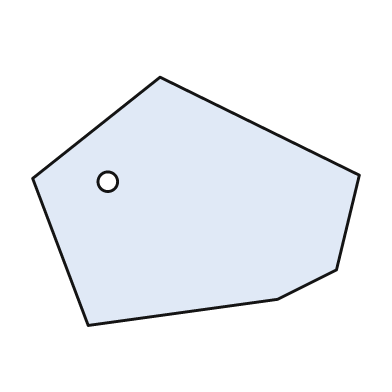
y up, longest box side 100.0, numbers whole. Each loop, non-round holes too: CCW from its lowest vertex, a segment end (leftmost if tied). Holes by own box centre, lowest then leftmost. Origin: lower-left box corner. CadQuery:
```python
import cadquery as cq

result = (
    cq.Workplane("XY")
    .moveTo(17.0, 0.0)
    .lineTo(75.0, 8.0)
    .lineTo(93.0, 17.0)
    .lineTo(100.0, 46.0)
    .lineTo(39.0, 76.0)
    .lineTo(0.0, 45.0)
    .close()
    .moveTo(23.0, 44.0)
    .circle(3.0)
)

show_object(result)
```